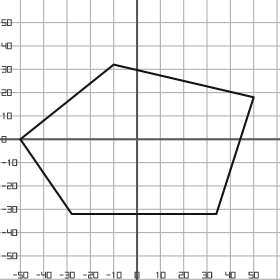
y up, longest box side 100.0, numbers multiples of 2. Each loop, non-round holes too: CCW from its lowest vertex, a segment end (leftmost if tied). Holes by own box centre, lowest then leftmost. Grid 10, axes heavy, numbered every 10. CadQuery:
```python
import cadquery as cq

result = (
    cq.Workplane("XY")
    .moveTo(-28.0, -32.0)
    .lineTo(34.0, -32.0)
    .lineTo(50.0, 18.0)
    .lineTo(-10.0, 32.0)
    .lineTo(-50.0, 0.0)
    .close()
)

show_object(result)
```